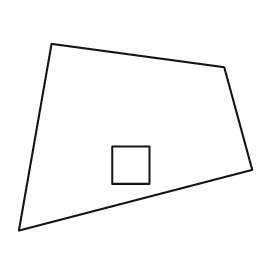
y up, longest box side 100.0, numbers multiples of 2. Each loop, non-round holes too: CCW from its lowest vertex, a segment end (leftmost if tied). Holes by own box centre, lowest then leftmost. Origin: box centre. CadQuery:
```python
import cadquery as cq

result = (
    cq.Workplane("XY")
    .moveTo(-50.0, -40.0)
    .lineTo(50.0, -14.0)
    .lineTo(38.0, 30.0)
    .lineTo(-36.0, 40.0)
    .close()
    .moveTo(-10.0, -20.0)
    .lineTo(6.0, -20.0)
    .lineTo(6.0, -4.0)
    .lineTo(-10.0, -4.0)
    .close()
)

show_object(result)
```